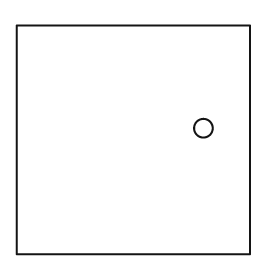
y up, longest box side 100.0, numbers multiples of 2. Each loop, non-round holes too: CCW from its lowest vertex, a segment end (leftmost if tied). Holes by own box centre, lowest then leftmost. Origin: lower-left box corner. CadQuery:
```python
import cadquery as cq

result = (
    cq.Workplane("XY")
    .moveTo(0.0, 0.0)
    .lineTo(100.0, 0.0)
    .lineTo(100.0, 98.0)
    .lineTo(0.0, 98.0)
    .close()
    .moveTo(80.0, 54.0)
    .circle(4.0)
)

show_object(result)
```